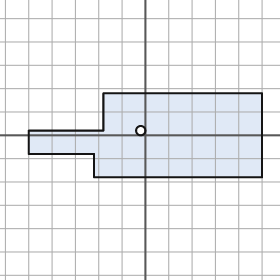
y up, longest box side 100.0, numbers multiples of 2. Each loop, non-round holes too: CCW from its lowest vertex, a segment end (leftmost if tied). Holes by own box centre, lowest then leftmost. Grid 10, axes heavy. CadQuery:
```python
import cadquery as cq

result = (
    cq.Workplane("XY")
    .moveTo(-22.0, -18.0)
    .lineTo(50.0, -18.0)
    .lineTo(50.0, 18.0)
    .lineTo(-18.0, 18.0)
    .lineTo(-18.0, 2.0)
    .lineTo(-50.0, 2.0)
    .lineTo(-50.0, -8.0)
    .lineTo(-22.0, -8.0)
    .close()
    .moveTo(-2.0, 2.0)
    .circle(2.0)
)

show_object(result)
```